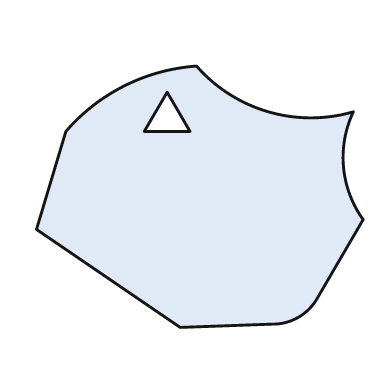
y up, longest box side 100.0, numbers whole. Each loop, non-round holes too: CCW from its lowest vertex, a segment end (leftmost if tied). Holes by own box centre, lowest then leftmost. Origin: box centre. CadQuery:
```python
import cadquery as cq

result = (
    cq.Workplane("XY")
    .moveTo(-6.0, -40.0)
    .lineTo(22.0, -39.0)
    .threePointArc((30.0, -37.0), (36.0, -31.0))
    .lineTo(50.0, -7.0)
    .threePointArc((44.0, 9.0), (47.0, 26.0))
    .threePointArc((21.0, 26.0), (-1.0, 40.0))
    .threePointArc((-23.0, 34.0), (-41.0, 20.0))
    .lineTo(-50.0, -10.0)
    .close()
    .moveTo(-17.0, 20.0)
    .lineTo(-3.0, 20.0)
    .lineTo(-10.0, 32.0)
    .close()
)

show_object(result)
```